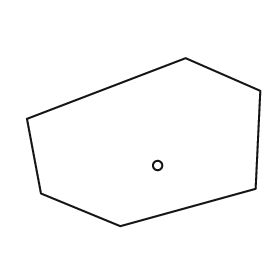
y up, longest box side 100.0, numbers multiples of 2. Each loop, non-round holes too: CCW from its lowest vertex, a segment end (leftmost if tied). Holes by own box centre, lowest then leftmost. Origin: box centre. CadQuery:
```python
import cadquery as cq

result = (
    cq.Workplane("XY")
    .moveTo(-10.0, -36.0)
    .lineTo(48.0, -20.0)
    .lineTo(50.0, 22.0)
    .lineTo(18.0, 36.0)
    .lineTo(-50.0, 10.0)
    .lineTo(-44.0, -22.0)
    .close()
    .moveTo(6.0, -10.0)
    .circle(2.0)
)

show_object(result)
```